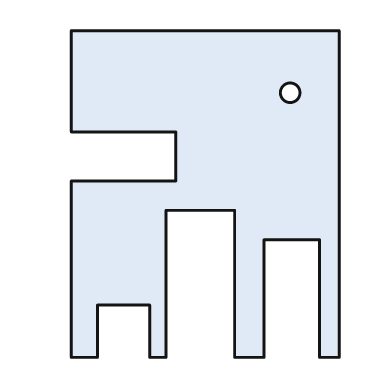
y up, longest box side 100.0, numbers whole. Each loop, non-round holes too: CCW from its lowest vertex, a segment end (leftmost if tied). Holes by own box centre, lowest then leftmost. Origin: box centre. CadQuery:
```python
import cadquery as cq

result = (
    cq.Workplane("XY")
    .moveTo(-41.0, -50.0)
    .lineTo(-33.0, -50.0)
    .lineTo(-33.0, -34.0)
    .lineTo(-17.0, -34.0)
    .lineTo(-17.0, -50.0)
    .lineTo(-12.0, -50.0)
    .lineTo(-12.0, -5.0)
    .lineTo(9.0, -5.0)
    .lineTo(9.0, -50.0)
    .lineTo(18.0, -50.0)
    .lineTo(18.0, -14.0)
    .lineTo(35.0, -14.0)
    .lineTo(35.0, -50.0)
    .lineTo(41.0, -50.0)
    .lineTo(41.0, 50.0)
    .lineTo(-41.0, 50.0)
    .lineTo(-41.0, 19.0)
    .lineTo(-9.0, 19.0)
    .lineTo(-9.0, 4.0)
    .lineTo(-41.0, 4.0)
    .close()
    .moveTo(26.0, 31.0)
    .circle(3.0)
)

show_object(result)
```